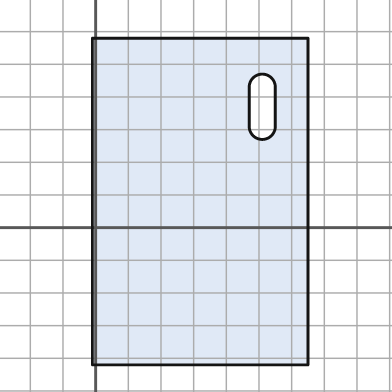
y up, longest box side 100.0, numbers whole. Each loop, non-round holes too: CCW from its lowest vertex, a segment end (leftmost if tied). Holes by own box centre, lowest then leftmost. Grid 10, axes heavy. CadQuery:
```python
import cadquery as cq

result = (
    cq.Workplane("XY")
    .moveTo(-1.0, -42.0)
    .lineTo(65.0, -42.0)
    .lineTo(65.0, 58.0)
    .lineTo(-1.0, 58.0)
    .close()
    .moveTo(47.0, 31.0)
    .threePointArc((51.0, 27.0), (55.0, 31.0))
    .lineTo(55.0, 43.0)
    .threePointArc((51.0, 47.0), (47.0, 43.0))
    .close()
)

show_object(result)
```